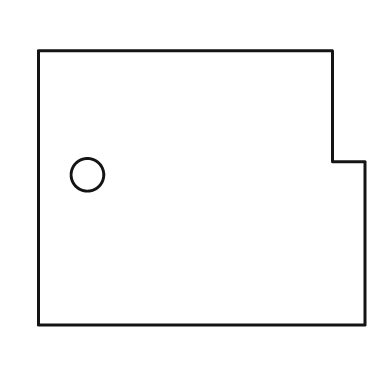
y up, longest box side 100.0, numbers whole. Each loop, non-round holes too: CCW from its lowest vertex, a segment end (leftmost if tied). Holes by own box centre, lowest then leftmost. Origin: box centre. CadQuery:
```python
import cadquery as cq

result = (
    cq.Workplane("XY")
    .moveTo(-50.0, -42.0)
    .lineTo(50.0, -42.0)
    .lineTo(50.0, 8.0)
    .lineTo(40.0, 8.0)
    .lineTo(40.0, 42.0)
    .lineTo(-50.0, 42.0)
    .close()
    .moveTo(-35.0, 4.0)
    .circle(5.0)
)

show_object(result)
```